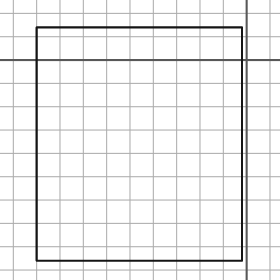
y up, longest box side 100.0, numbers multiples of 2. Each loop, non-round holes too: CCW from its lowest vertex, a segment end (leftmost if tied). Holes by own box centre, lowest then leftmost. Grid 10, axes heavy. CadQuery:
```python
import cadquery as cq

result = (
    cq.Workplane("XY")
    .moveTo(-90.0, -86.0)
    .lineTo(-2.0, -86.0)
    .lineTo(-2.0, 14.0)
    .lineTo(-90.0, 14.0)
    .close()
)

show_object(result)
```